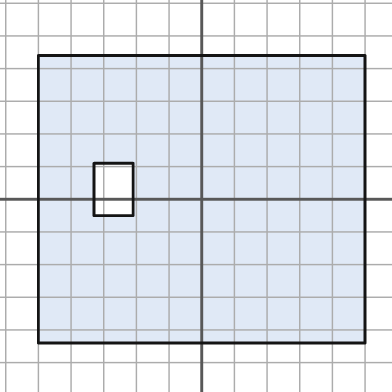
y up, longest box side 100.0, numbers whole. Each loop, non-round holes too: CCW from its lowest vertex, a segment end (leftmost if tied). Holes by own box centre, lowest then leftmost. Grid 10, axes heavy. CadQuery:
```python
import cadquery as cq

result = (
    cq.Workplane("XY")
    .moveTo(-50.0, -44.0)
    .lineTo(50.0, -44.0)
    .lineTo(50.0, 44.0)
    .lineTo(-50.0, 44.0)
    .close()
    .moveTo(-33.0, -5.0)
    .lineTo(-21.0, -5.0)
    .lineTo(-21.0, 11.0)
    .lineTo(-33.0, 11.0)
    .close()
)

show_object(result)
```